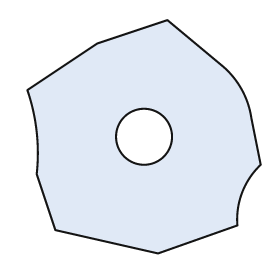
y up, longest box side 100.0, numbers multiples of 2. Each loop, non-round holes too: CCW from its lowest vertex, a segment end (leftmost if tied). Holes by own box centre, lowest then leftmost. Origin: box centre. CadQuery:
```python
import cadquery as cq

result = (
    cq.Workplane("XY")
    .moveTo(6.0, -50.0)
    .lineTo(40.0, -38.0)
    .threePointArc((42.0, -24.0), (50.0, -12.0))
    .lineTo(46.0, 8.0)
    .threePointArc((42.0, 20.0), (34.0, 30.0))
    .lineTo(10.0, 50.0)
    .lineTo(-20.0, 40.0)
    .lineTo(-50.0, 20.0)
    .threePointArc((-46.0, 2.0), (-46.0, -16.0))
    .lineTo(-38.0, -40.0)
    .close()
    .moveTo(0.0, 0.0)
    .circle(12.0)
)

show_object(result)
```